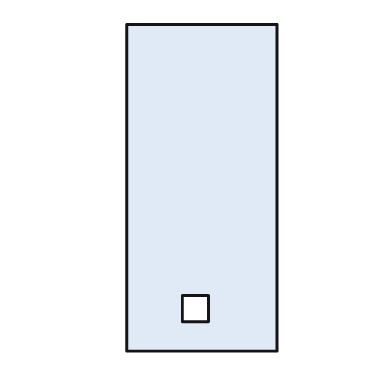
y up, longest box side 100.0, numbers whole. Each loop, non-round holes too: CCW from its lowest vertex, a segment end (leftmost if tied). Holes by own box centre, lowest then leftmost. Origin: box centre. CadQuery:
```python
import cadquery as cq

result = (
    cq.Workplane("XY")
    .moveTo(-23.0, -50.0)
    .lineTo(23.0, -50.0)
    .lineTo(23.0, 50.0)
    .lineTo(-23.0, 50.0)
    .close()
    .moveTo(-6.0, -41.0)
    .lineTo(2.0, -41.0)
    .lineTo(2.0, -33.0)
    .lineTo(-6.0, -33.0)
    .close()
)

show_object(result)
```